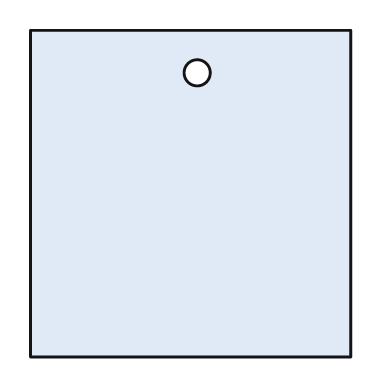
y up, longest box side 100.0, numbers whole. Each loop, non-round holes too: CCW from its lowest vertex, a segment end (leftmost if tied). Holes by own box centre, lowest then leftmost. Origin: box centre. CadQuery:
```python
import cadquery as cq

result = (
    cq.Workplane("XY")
    .moveTo(-49.0, -50.0)
    .lineTo(49.0, -50.0)
    .lineTo(49.0, 50.0)
    .lineTo(-49.0, 50.0)
    .close()
    .moveTo(2.0, 37.0)
    .circle(4.0)
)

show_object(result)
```